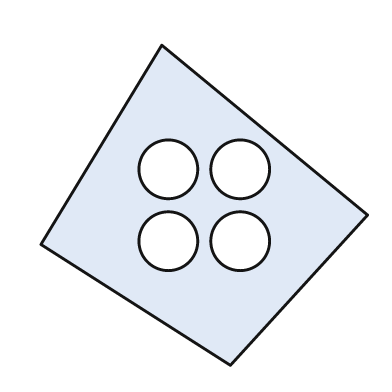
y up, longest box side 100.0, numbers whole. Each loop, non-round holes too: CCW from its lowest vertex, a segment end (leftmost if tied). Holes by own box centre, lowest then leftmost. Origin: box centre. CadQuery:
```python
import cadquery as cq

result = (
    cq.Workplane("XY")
    .moveTo(8.0, -49.0)
    .lineTo(50.0, -3.0)
    .lineTo(-13.0, 49.0)
    .lineTo(-50.0, -12.0)
    .close()
    .moveTo(-11.0, -11.0)
    .circle(9.0)
    .moveTo(11.0, -11.0)
    .circle(9.0)
    .moveTo(-11.0, 11.0)
    .circle(9.0)
    .moveTo(11.0, 11.0)
    .circle(9.0)
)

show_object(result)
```